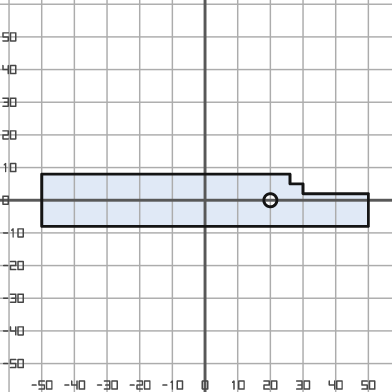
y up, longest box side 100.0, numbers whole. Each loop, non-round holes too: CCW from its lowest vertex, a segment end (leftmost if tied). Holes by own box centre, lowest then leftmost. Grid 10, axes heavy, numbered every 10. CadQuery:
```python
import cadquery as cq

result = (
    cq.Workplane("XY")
    .moveTo(-50.0, -8.0)
    .lineTo(50.0, -8.0)
    .lineTo(50.0, 2.0)
    .lineTo(30.0, 2.0)
    .lineTo(30.0, 5.0)
    .lineTo(26.0, 5.0)
    .lineTo(26.0, 8.0)
    .lineTo(-50.0, 8.0)
    .close()
    .moveTo(20.0, 0.0)
    .circle(2.0)
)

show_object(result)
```